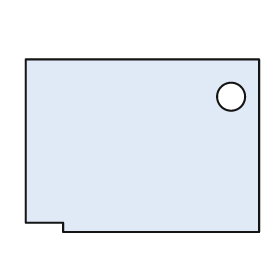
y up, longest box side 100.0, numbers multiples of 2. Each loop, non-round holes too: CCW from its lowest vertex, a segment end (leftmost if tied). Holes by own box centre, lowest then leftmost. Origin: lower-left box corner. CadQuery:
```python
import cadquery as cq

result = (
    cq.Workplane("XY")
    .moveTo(16.0, 0.0)
    .lineTo(100.0, 0.0)
    .lineTo(100.0, 74.0)
    .lineTo(0.0, 74.0)
    .lineTo(0.0, 4.0)
    .lineTo(16.0, 4.0)
    .close()
    .moveTo(88.0, 58.0)
    .circle(6.0)
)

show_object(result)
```